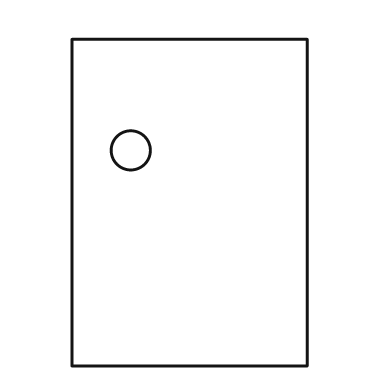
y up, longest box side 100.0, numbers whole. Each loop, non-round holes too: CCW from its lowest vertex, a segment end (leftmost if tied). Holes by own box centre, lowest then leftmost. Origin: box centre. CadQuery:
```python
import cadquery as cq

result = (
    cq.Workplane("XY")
    .moveTo(-36.0, -50.0)
    .lineTo(36.0, -50.0)
    .lineTo(36.0, 50.0)
    .lineTo(-36.0, 50.0)
    .close()
    .moveTo(-18.0, 16.0)
    .circle(6.0)
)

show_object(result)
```